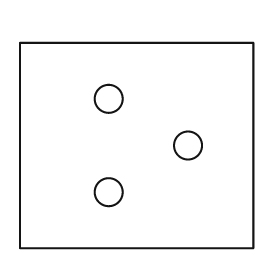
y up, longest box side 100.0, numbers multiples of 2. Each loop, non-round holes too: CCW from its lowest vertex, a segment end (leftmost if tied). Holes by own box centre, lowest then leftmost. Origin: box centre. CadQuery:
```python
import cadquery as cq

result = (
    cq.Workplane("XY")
    .moveTo(-50.0, -44.0)
    .lineTo(50.0, -44.0)
    .lineTo(50.0, 44.0)
    .lineTo(-50.0, 44.0)
    .close()
    .moveTo(-12.0, -20.0)
    .circle(6.0)
    .moveTo(22.0, 0.0)
    .circle(6.0)
    .moveTo(-12.0, 20.0)
    .circle(6.0)
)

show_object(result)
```